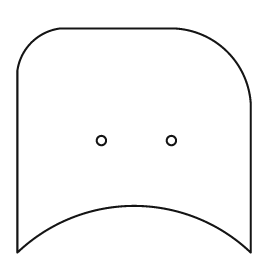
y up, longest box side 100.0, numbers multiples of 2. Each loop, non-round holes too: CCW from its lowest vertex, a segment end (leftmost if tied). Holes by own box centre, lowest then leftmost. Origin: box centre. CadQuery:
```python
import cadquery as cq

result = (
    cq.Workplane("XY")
    .moveTo(-50.0, -48.0)
    .threePointArc((0.0, -28.0), (50.0, -48.0))
    .lineTo(50.0, 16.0)
    .threePointArc((40.0, 38.0), (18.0, 48.0))
    .lineTo(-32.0, 48.0)
    .threePointArc((-44.0, 42.0), (-50.0, 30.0))
    .close()
    .moveTo(-14.0, 0.0)
    .circle(2.0)
    .moveTo(16.0, 0.0)
    .circle(2.0)
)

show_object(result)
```